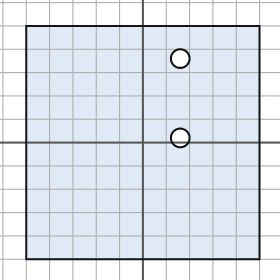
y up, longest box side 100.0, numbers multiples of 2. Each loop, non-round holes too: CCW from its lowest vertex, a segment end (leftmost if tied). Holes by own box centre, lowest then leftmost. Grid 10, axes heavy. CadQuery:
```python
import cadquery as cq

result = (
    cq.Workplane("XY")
    .moveTo(-50.0, -50.0)
    .lineTo(50.0, -50.0)
    .lineTo(50.0, 50.0)
    .lineTo(-50.0, 50.0)
    .close()
    .moveTo(16.0, 2.0)
    .circle(4.0)
    .moveTo(16.0, 36.0)
    .circle(4.0)
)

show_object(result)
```